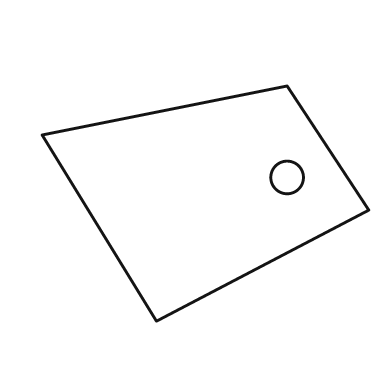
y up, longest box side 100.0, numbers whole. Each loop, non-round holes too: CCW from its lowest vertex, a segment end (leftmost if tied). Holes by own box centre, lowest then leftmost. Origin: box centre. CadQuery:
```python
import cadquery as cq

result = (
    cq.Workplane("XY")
    .moveTo(-15.0, -36.0)
    .lineTo(50.0, -2.0)
    .lineTo(25.0, 36.0)
    .lineTo(-50.0, 21.0)
    .close()
    .moveTo(25.0, 8.0)
    .circle(5.0)
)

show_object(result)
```